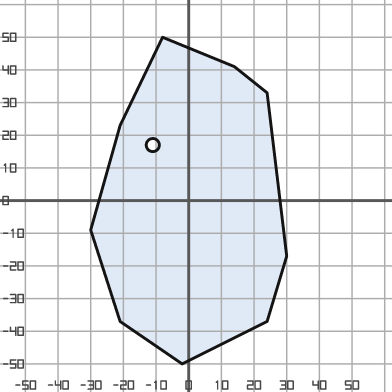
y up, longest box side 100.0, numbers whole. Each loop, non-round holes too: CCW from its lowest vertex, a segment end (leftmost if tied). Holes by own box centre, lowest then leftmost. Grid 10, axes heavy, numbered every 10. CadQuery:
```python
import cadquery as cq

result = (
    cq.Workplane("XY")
    .moveTo(-2.0, -50.0)
    .lineTo(24.0, -37.0)
    .lineTo(30.0, -17.0)
    .lineTo(24.0, 33.0)
    .lineTo(14.0, 41.0)
    .lineTo(-8.0, 50.0)
    .lineTo(-21.0, 23.0)
    .lineTo(-30.0, -9.0)
    .lineTo(-21.0, -37.0)
    .close()
    .moveTo(-11.0, 17.0)
    .circle(2.0)
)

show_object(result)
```